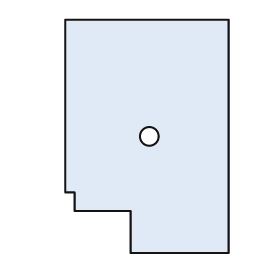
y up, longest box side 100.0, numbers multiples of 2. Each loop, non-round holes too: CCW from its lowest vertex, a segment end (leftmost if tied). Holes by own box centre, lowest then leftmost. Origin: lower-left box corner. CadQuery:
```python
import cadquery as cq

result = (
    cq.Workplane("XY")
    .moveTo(28.0, 0.0)
    .lineTo(70.0, 0.0)
    .lineTo(70.0, 100.0)
    .lineTo(0.0, 100.0)
    .lineTo(0.0, 26.0)
    .lineTo(4.0, 26.0)
    .lineTo(4.0, 18.0)
    .lineTo(28.0, 18.0)
    .close()
    .moveTo(36.0, 50.0)
    .circle(4.0)
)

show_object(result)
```